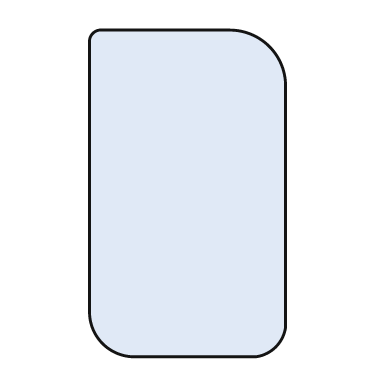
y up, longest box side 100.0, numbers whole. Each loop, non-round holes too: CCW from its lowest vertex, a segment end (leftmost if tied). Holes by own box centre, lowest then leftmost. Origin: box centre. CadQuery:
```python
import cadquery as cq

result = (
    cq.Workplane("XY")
    .moveTo(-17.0, -50.0)
    .lineTo(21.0, -50.0)
    .threePointArc((27.0, -47.0), (30.0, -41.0))
    .lineTo(30.0, 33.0)
    .threePointArc((25.0, 45.0), (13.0, 50.0))
    .lineTo(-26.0, 50.0)
    .threePointArc((-29.0, 49.0), (-30.0, 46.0))
    .lineTo(-30.0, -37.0)
    .threePointArc((-26.0, -46.0), (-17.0, -50.0))
    .close()
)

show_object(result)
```